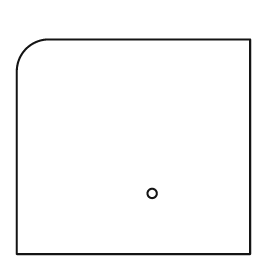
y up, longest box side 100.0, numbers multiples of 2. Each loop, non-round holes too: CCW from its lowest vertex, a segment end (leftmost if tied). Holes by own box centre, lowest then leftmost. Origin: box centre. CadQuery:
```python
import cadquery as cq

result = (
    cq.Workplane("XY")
    .moveTo(-50.0, -46.0)
    .lineTo(50.0, -46.0)
    .lineTo(50.0, 46.0)
    .lineTo(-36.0, 46.0)
    .threePointArc((-46.0, 42.0), (-50.0, 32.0))
    .close()
    .moveTo(8.0, -20.0)
    .circle(2.0)
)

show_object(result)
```